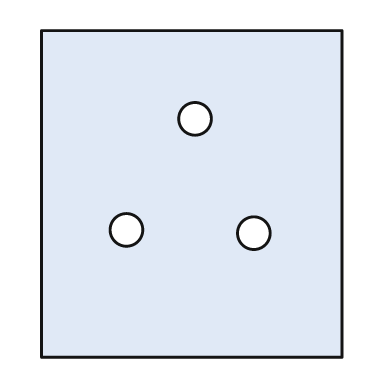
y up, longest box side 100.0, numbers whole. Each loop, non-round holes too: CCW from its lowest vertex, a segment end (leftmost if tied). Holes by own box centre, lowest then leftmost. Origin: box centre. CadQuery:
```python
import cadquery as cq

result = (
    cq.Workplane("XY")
    .moveTo(-46.0, -50.0)
    .lineTo(46.0, -50.0)
    .lineTo(46.0, 50.0)
    .lineTo(-46.0, 50.0)
    .close()
    .moveTo(19.0, -12.0)
    .circle(5.0)
    .moveTo(-20.0, -11.0)
    .circle(5.0)
    .moveTo(1.0, 23.0)
    .circle(5.0)
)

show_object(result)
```